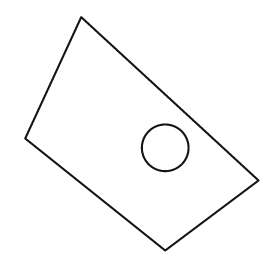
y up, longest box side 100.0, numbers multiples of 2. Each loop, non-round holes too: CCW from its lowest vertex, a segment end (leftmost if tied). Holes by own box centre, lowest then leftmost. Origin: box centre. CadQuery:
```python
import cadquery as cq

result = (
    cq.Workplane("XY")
    .moveTo(10.0, -50.0)
    .lineTo(50.0, -20.0)
    .lineTo(-26.0, 50.0)
    .lineTo(-50.0, -2.0)
    .close()
    .moveTo(10.0, -6.0)
    .circle(10.0)
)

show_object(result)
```